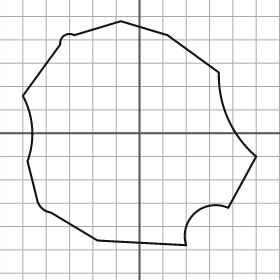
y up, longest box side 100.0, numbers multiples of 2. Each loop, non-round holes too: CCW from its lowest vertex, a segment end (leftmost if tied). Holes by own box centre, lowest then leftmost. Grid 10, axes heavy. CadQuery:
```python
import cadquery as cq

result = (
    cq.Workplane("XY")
    .moveTo(20.0, -48.0)
    .threePointArc((24.0, -34.0), (38.0, -32.0))
    .lineTo(50.0, -10.0)
    .threePointArc((38.0, 6.0), (34.0, 26.0))
    .lineTo(12.0, 42.0)
    .lineTo(-8.0, 48.0)
    .lineTo(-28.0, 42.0)
    .threePointArc((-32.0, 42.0), (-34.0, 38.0))
    .lineTo(-50.0, 16.0)
    .threePointArc((-46.0, 2.0), (-48.0, -12.0))
    .lineTo(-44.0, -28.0)
    .threePointArc((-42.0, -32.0), (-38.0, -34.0))
    .lineTo(-18.0, -46.0)
    .close()
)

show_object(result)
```